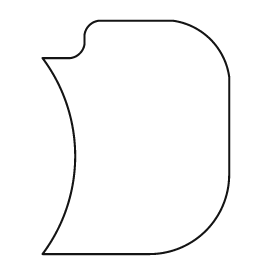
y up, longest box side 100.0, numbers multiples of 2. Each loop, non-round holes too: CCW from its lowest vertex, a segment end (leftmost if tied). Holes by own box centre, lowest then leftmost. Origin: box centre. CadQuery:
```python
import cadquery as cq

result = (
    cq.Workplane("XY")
    .moveTo(-40.0, -50.0)
    .lineTo(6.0, -50.0)
    .threePointArc((30.0, -40.0), (40.0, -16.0))
    .lineTo(40.0, 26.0)
    .threePointArc((32.0, 42.0), (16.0, 50.0))
    .lineTo(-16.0, 50.0)
    .threePointArc((-20.0, 48.0), (-22.0, 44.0))
    .lineTo(-22.0, 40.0)
    .threePointArc((-24.0, 36.0), (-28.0, 34.0))
    .lineTo(-40.0, 34.0)
    .threePointArc((-26.0, -8.0), (-40.0, -50.0))
    .close()
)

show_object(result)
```